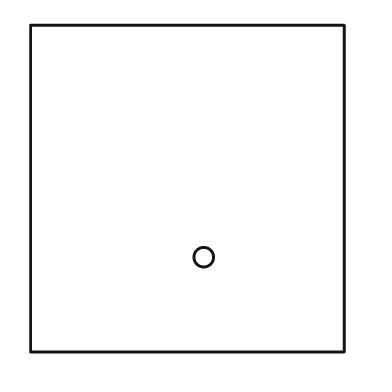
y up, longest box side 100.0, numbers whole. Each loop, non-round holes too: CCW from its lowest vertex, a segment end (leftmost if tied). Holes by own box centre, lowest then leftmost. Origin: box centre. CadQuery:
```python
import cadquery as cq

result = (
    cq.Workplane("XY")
    .moveTo(-48.0, -50.0)
    .lineTo(48.0, -50.0)
    .lineTo(48.0, 50.0)
    .lineTo(-48.0, 50.0)
    .close()
    .moveTo(5.0, -21.0)
    .circle(3.0)
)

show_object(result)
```